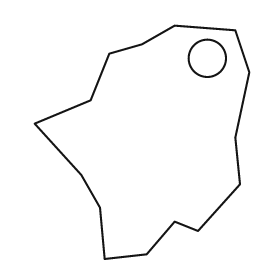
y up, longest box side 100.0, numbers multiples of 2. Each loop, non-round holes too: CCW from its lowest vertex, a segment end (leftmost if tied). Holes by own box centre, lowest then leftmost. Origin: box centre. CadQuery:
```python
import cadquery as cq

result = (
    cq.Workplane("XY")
    .moveTo(-16.0, -50.0)
    .lineTo(2.0, -48.0)
    .lineTo(14.0, -34.0)
    .lineTo(24.0, -38.0)
    .lineTo(42.0, -18.0)
    .lineTo(40.0, 2.0)
    .lineTo(46.0, 30.0)
    .lineTo(40.0, 48.0)
    .lineTo(14.0, 50.0)
    .lineTo(0.0, 42.0)
    .lineTo(-14.0, 38.0)
    .lineTo(-22.0, 18.0)
    .lineTo(-46.0, 8.0)
    .lineTo(-26.0, -14.0)
    .lineTo(-18.0, -28.0)
    .close()
    .moveTo(28.0, 36.0)
    .circle(8.0)
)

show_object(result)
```